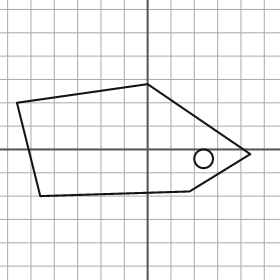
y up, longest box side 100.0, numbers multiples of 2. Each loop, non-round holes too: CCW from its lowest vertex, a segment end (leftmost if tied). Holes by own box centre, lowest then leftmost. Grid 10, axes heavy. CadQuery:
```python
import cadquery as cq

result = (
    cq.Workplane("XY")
    .moveTo(-46.0, -20.0)
    .lineTo(18.0, -18.0)
    .lineTo(44.0, -2.0)
    .lineTo(0.0, 28.0)
    .lineTo(-56.0, 20.0)
    .close()
    .moveTo(24.0, -4.0)
    .circle(4.0)
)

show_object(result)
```